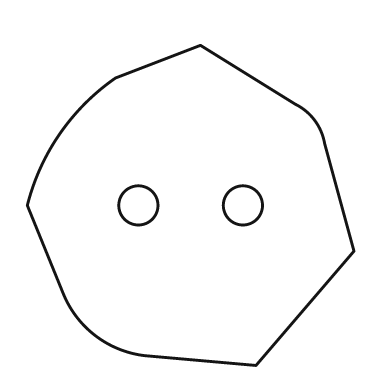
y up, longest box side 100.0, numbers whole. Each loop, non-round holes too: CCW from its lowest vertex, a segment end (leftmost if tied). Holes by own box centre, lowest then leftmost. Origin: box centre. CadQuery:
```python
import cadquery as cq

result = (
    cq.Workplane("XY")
    .moveTo(20.0, -49.0)
    .lineTo(50.0, -14.0)
    .lineTo(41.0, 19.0)
    .threePointArc((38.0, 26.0), (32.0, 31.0))
    .lineTo(3.0, 49.0)
    .lineTo(-23.0, 39.0)
    .threePointArc((-40.0, 22.0), (-50.0, 0.0))
    .lineTo(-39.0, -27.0)
    .threePointArc((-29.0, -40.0), (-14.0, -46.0))
    .close()
    .moveTo(-16.0, 0.0)
    .circle(6.0)
    .moveTo(16.0, 0.0)
    .circle(6.0)
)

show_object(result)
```